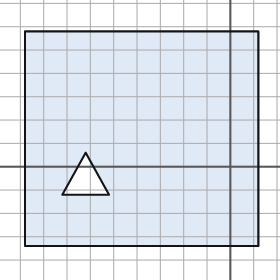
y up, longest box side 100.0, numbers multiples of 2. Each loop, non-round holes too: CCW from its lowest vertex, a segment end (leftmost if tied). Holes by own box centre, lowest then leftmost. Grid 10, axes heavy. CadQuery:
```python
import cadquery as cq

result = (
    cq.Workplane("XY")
    .moveTo(-88.0, -34.0)
    .lineTo(12.0, -34.0)
    .lineTo(12.0, 58.0)
    .lineTo(-88.0, 58.0)
    .close()
    .moveTo(-72.0, -12.0)
    .lineTo(-52.0, -12.0)
    .lineTo(-62.0, 6.0)
    .close()
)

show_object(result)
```